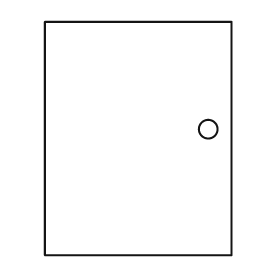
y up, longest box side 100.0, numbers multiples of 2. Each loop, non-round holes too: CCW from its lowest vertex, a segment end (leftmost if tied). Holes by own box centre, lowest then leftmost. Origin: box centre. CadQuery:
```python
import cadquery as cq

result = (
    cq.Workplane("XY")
    .moveTo(-40.0, -50.0)
    .lineTo(40.0, -50.0)
    .lineTo(40.0, 50.0)
    .lineTo(-40.0, 50.0)
    .close()
    .moveTo(30.0, 4.0)
    .circle(4.0)
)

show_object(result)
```